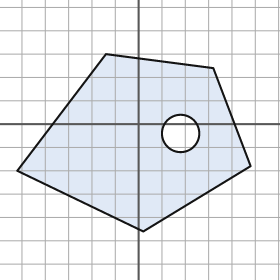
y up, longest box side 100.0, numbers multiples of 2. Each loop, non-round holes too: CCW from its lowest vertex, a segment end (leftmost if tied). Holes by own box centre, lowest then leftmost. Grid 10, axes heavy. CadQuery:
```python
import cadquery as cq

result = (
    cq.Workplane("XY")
    .moveTo(2.0, -46.0)
    .lineTo(48.0, -18.0)
    .lineTo(32.0, 24.0)
    .lineTo(-14.0, 30.0)
    .lineTo(-52.0, -20.0)
    .close()
    .moveTo(18.0, -4.0)
    .circle(8.0)
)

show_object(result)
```